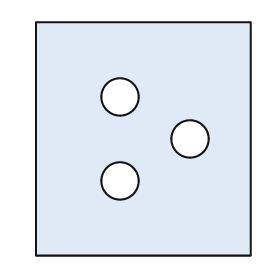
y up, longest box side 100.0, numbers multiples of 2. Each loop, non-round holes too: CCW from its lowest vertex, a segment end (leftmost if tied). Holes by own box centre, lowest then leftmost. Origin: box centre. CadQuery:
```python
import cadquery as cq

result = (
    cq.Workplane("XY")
    .moveTo(-46.0, -50.0)
    .lineTo(46.0, -50.0)
    .lineTo(46.0, 50.0)
    .lineTo(-46.0, 50.0)
    .close()
    .moveTo(-10.0, -18.0)
    .circle(8.0)
    .moveTo(20.0, 0.0)
    .circle(8.0)
    .moveTo(-10.0, 18.0)
    .circle(8.0)
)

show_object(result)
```